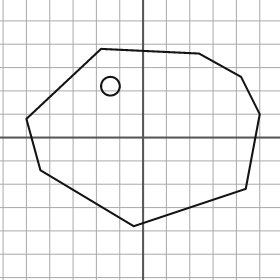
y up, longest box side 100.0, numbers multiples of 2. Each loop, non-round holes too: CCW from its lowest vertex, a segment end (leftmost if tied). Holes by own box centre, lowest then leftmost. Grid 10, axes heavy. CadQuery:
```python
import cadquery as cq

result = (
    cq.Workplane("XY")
    .moveTo(-4.0, -38.0)
    .lineTo(44.0, -22.0)
    .lineTo(50.0, 10.0)
    .lineTo(42.0, 26.0)
    .lineTo(24.0, 36.0)
    .lineTo(-18.0, 38.0)
    .lineTo(-50.0, 8.0)
    .lineTo(-44.0, -14.0)
    .close()
    .moveTo(-14.0, 22.0)
    .circle(4.0)
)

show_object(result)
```